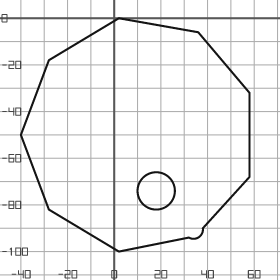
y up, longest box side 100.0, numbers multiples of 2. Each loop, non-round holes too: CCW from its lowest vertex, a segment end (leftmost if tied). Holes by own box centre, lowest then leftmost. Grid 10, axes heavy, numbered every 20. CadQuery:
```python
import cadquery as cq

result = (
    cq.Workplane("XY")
    .moveTo(2.0, -100.0)
    .lineTo(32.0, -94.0)
    .threePointArc((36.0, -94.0), (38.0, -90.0))
    .lineTo(58.0, -68.0)
    .lineTo(58.0, -32.0)
    .lineTo(36.0, -6.0)
    .lineTo(2.0, 0.0)
    .lineTo(-28.0, -18.0)
    .lineTo(-40.0, -50.0)
    .lineTo(-28.0, -82.0)
    .close()
    .moveTo(18.0, -74.0)
    .circle(8.0)
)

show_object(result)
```